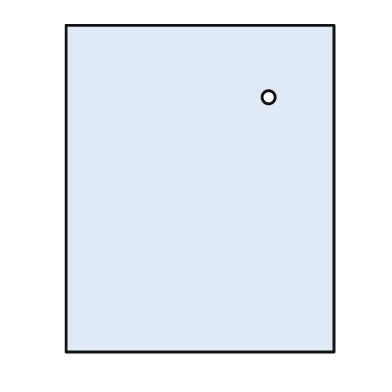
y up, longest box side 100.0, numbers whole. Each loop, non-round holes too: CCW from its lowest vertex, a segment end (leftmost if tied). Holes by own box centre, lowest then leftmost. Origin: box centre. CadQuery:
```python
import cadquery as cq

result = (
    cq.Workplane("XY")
    .moveTo(-41.0, -50.0)
    .lineTo(41.0, -50.0)
    .lineTo(41.0, 50.0)
    .lineTo(-41.0, 50.0)
    .close()
    .moveTo(21.0, 28.0)
    .circle(2.0)
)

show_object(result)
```